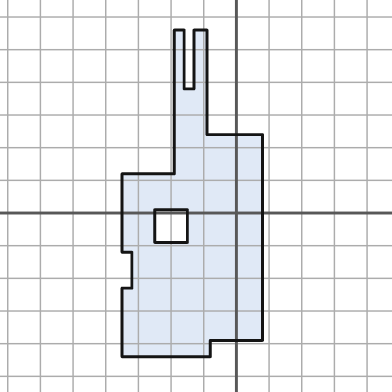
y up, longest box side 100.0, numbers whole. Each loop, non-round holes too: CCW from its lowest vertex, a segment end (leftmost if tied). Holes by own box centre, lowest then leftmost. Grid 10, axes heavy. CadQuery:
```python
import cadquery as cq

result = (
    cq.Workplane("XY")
    .moveTo(-35.0, -44.0)
    .lineTo(-8.0, -44.0)
    .lineTo(-8.0, -39.0)
    .lineTo(8.0, -39.0)
    .lineTo(8.0, 24.0)
    .lineTo(-9.0, 24.0)
    .lineTo(-9.0, 56.0)
    .lineTo(-13.0, 56.0)
    .lineTo(-13.0, 38.0)
    .lineTo(-16.0, 38.0)
    .lineTo(-16.0, 56.0)
    .lineTo(-19.0, 56.0)
    .lineTo(-19.0, 12.0)
    .lineTo(-35.0, 12.0)
    .lineTo(-35.0, -12.0)
    .lineTo(-32.0, -12.0)
    .lineTo(-32.0, -23.0)
    .lineTo(-35.0, -23.0)
    .close()
    .moveTo(-25.0, -9.0)
    .lineTo(-15.0, -9.0)
    .lineTo(-15.0, 1.0)
    .lineTo(-25.0, 1.0)
    .close()
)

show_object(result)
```